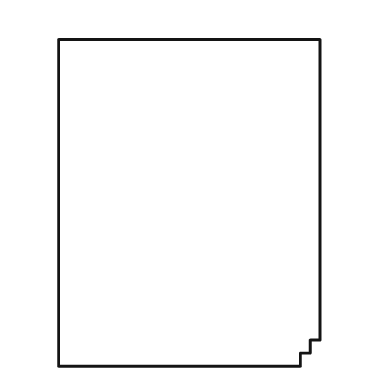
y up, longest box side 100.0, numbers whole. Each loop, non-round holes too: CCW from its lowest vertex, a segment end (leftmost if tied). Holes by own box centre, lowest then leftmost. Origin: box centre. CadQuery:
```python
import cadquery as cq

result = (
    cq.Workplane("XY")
    .moveTo(-40.0, -50.0)
    .lineTo(34.0, -50.0)
    .lineTo(34.0, -46.0)
    .lineTo(37.0, -46.0)
    .lineTo(37.0, -42.0)
    .lineTo(40.0, -42.0)
    .lineTo(40.0, 50.0)
    .lineTo(-40.0, 50.0)
    .close()
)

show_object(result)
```